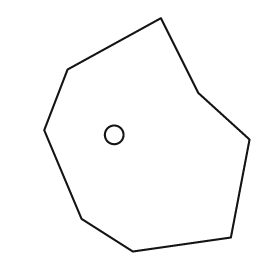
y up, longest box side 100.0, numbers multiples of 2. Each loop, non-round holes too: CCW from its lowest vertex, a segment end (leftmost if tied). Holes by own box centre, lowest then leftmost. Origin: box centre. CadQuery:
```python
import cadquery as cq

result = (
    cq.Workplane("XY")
    .moveTo(-6.0, -50.0)
    .lineTo(36.0, -44.0)
    .lineTo(44.0, -2.0)
    .lineTo(22.0, 18.0)
    .lineTo(6.0, 50.0)
    .lineTo(-34.0, 28.0)
    .lineTo(-44.0, 2.0)
    .lineTo(-28.0, -36.0)
    .close()
    .moveTo(-14.0, 0.0)
    .circle(4.0)
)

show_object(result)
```